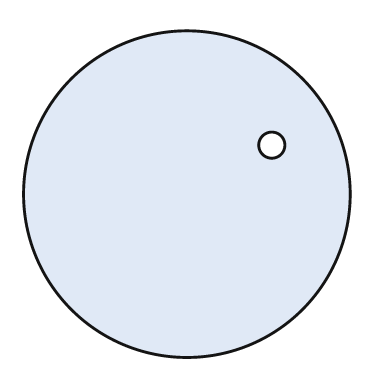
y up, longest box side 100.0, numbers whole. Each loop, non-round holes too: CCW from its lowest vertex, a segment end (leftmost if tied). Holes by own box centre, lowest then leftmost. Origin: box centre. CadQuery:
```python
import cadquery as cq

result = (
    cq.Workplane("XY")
    .moveTo(0.0, 0.0)
    .circle(50.0)
    .moveTo(26.0, 15.0)
    .circle(4.0)
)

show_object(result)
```